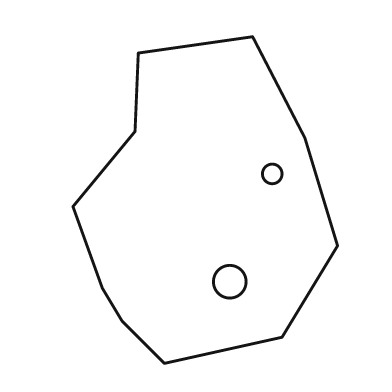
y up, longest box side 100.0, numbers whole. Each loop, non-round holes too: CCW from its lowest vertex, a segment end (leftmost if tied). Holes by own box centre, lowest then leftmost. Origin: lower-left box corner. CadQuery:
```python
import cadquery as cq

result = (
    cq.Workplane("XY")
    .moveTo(28.0, 0.0)
    .lineTo(64.0, 8.0)
    .lineTo(81.0, 36.0)
    .lineTo(71.0, 69.0)
    .lineTo(55.0, 100.0)
    .lineTo(20.0, 95.0)
    .lineTo(19.0, 71.0)
    .lineTo(0.0, 48.0)
    .lineTo(9.0, 23.0)
    .lineTo(15.0, 13.0)
    .close()
    .moveTo(48.0, 25.0)
    .circle(5.0)
    .moveTo(61.0, 58.0)
    .circle(3.0)
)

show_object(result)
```